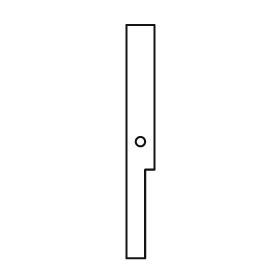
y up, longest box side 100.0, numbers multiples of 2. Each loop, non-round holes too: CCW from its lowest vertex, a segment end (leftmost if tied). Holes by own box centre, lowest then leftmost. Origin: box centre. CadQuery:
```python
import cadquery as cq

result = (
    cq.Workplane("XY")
    .moveTo(-6.0, -50.0)
    .lineTo(2.0, -50.0)
    .lineTo(2.0, -12.0)
    .lineTo(6.0, -12.0)
    .lineTo(6.0, 50.0)
    .lineTo(-6.0, 50.0)
    .close()
    .moveTo(0.0, 0.0)
    .circle(2.0)
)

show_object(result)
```